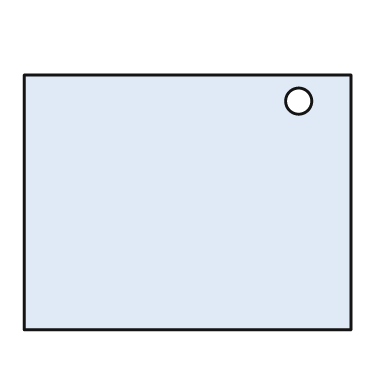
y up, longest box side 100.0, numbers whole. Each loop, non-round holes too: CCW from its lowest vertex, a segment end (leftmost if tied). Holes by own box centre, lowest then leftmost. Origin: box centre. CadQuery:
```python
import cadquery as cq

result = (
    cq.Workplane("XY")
    .moveTo(-50.0, -39.0)
    .lineTo(50.0, -39.0)
    .lineTo(50.0, 39.0)
    .lineTo(-50.0, 39.0)
    .close()
    .moveTo(34.0, 31.0)
    .circle(4.0)
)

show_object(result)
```